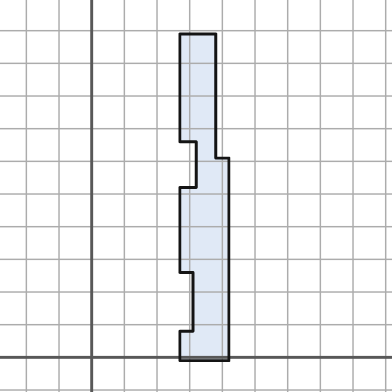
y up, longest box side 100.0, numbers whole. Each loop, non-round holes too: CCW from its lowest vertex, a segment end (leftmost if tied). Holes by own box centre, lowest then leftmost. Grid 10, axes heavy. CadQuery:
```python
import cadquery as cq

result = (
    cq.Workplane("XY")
    .moveTo(27.0, -1.0)
    .lineTo(42.0, -1.0)
    .lineTo(42.0, 61.0)
    .lineTo(38.0, 61.0)
    .lineTo(38.0, 99.0)
    .lineTo(27.0, 99.0)
    .lineTo(27.0, 66.0)
    .lineTo(32.0, 66.0)
    .lineTo(32.0, 52.0)
    .lineTo(27.0, 52.0)
    .lineTo(27.0, 26.0)
    .lineTo(31.0, 26.0)
    .lineTo(31.0, 8.0)
    .lineTo(27.0, 8.0)
    .close()
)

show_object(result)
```